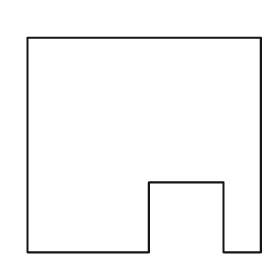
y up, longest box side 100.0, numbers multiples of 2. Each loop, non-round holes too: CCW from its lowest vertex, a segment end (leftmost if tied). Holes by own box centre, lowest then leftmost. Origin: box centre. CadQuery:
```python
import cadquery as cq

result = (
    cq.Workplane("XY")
    .moveTo(-50.0, -46.0)
    .lineTo(2.0, -46.0)
    .lineTo(2.0, -16.0)
    .lineTo(34.0, -16.0)
    .lineTo(34.0, -46.0)
    .lineTo(50.0, -46.0)
    .lineTo(50.0, 46.0)
    .lineTo(-50.0, 46.0)
    .close()
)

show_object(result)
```